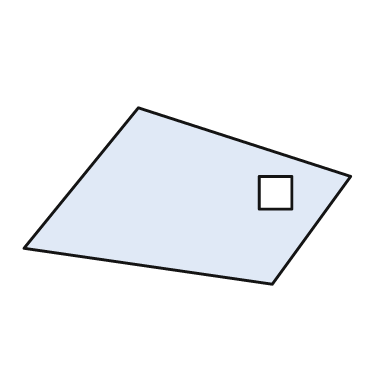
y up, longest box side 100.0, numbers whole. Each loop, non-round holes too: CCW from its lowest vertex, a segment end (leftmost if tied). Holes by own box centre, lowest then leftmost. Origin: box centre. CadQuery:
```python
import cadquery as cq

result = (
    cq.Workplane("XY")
    .moveTo(26.0, -27.0)
    .lineTo(50.0, 6.0)
    .lineTo(-15.0, 27.0)
    .lineTo(-50.0, -16.0)
    .close()
    .moveTo(22.0, -4.0)
    .lineTo(32.0, -4.0)
    .lineTo(32.0, 6.0)
    .lineTo(22.0, 6.0)
    .close()
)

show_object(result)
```